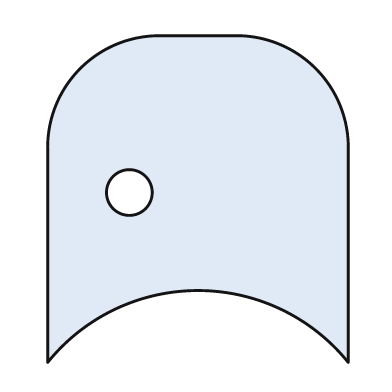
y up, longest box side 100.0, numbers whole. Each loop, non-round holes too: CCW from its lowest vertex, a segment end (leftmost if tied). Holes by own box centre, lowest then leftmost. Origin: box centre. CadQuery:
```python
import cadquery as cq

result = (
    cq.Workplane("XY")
    .moveTo(-46.0, -50.0)
    .threePointArc((0.0, -28.0), (46.0, -50.0))
    .lineTo(46.0, 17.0)
    .threePointArc((36.0, 40.0), (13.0, 50.0))
    .lineTo(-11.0, 50.0)
    .threePointArc((-36.0, 40.0), (-46.0, 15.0))
    .close()
    .moveTo(-21.0, 2.0)
    .circle(7.0)
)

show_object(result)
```